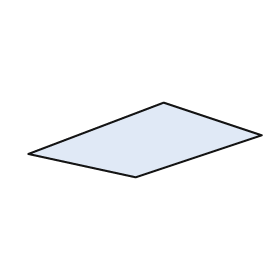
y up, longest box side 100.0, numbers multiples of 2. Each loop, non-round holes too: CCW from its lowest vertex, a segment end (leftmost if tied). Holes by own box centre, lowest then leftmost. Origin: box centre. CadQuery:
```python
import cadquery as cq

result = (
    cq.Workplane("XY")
    .moveTo(-4.0, -16.0)
    .lineTo(50.0, 2.0)
    .lineTo(8.0, 16.0)
    .lineTo(-50.0, -6.0)
    .close()
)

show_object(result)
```